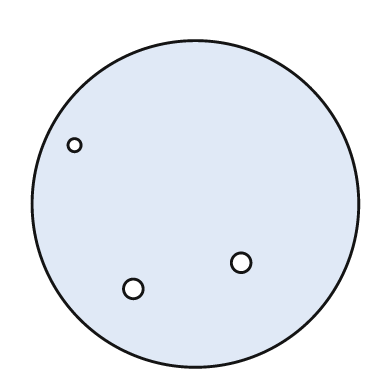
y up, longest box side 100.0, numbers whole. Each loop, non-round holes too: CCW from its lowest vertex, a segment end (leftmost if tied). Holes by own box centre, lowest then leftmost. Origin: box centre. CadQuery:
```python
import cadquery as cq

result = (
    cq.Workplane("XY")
    .moveTo(0.0, 0.0)
    .circle(50.0)
    .moveTo(-19.0, -26.0)
    .circle(3.0)
    .moveTo(14.0, -18.0)
    .circle(3.0)
    .moveTo(-37.0, 18.0)
    .circle(2.0)
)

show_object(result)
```